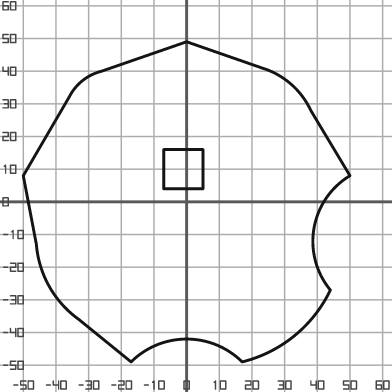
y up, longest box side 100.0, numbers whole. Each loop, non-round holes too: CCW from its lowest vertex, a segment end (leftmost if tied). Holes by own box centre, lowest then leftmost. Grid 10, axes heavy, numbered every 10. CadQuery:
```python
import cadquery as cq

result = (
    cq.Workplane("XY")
    .moveTo(-17.0, -49.0)
    .threePointArc((0.0, -42.0), (17.0, -49.0))
    .threePointArc((33.0, -41.0), (44.0, -27.0))
    .threePointArc((39.0, -8.0), (50.0, 8.0))
    .lineTo(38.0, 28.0)
    .threePointArc((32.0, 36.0), (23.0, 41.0))
    .lineTo(0.0, 49.0)
    .lineTo(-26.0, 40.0)
    .threePointArc((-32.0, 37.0), (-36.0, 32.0))
    .lineTo(-50.0, 8.0)
    .lineTo(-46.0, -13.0)
    .threePointArc((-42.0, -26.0), (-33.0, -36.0))
    .close()
    .moveTo(-7.0, 4.0)
    .lineTo(5.0, 4.0)
    .lineTo(5.0, 16.0)
    .lineTo(-7.0, 16.0)
    .close()
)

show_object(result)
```